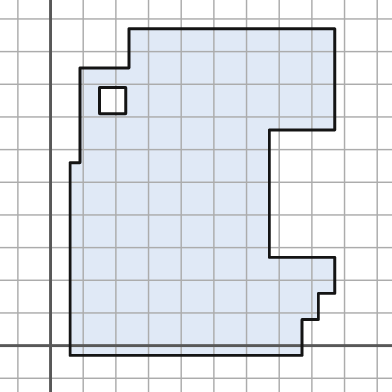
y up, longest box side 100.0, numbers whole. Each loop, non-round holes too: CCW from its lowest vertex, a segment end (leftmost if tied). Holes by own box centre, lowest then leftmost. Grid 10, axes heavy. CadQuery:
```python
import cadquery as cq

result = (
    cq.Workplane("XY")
    .moveTo(6.0, -3.0)
    .lineTo(77.0, -3.0)
    .lineTo(77.0, 8.0)
    .lineTo(82.0, 8.0)
    .lineTo(82.0, 16.0)
    .lineTo(87.0, 16.0)
    .lineTo(87.0, 27.0)
    .lineTo(67.0, 27.0)
    .lineTo(67.0, 66.0)
    .lineTo(87.0, 66.0)
    .lineTo(87.0, 97.0)
    .lineTo(24.0, 97.0)
    .lineTo(24.0, 85.0)
    .lineTo(9.0, 85.0)
    .lineTo(9.0, 56.0)
    .lineTo(6.0, 56.0)
    .close()
    .moveTo(15.0, 71.0)
    .lineTo(23.0, 71.0)
    .lineTo(23.0, 79.0)
    .lineTo(15.0, 79.0)
    .close()
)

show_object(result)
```